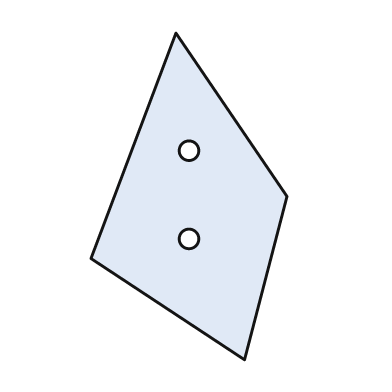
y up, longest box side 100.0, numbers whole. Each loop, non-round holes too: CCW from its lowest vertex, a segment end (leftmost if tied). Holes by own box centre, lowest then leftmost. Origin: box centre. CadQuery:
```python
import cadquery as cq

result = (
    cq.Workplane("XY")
    .moveTo(17.0, -50.0)
    .lineTo(30.0, 0.0)
    .lineTo(-4.0, 50.0)
    .lineTo(-30.0, -19.0)
    .close()
    .moveTo(0.0, -13.0)
    .circle(3.0)
    .moveTo(0.0, 14.0)
    .circle(3.0)
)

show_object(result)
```